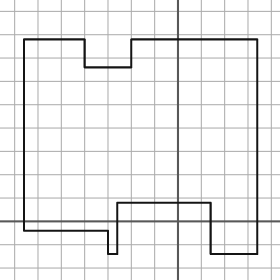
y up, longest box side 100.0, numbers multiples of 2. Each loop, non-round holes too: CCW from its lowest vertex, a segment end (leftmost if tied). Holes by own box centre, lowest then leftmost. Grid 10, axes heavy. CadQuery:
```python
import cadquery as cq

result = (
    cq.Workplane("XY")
    .moveTo(-30.0, -14.0)
    .lineTo(-26.0, -14.0)
    .lineTo(-26.0, 8.0)
    .lineTo(14.0, 8.0)
    .lineTo(14.0, -14.0)
    .lineTo(34.0, -14.0)
    .lineTo(34.0, 78.0)
    .lineTo(-20.0, 78.0)
    .lineTo(-20.0, 66.0)
    .lineTo(-40.0, 66.0)
    .lineTo(-40.0, 78.0)
    .lineTo(-66.0, 78.0)
    .lineTo(-66.0, -4.0)
    .lineTo(-30.0, -4.0)
    .close()
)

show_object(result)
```